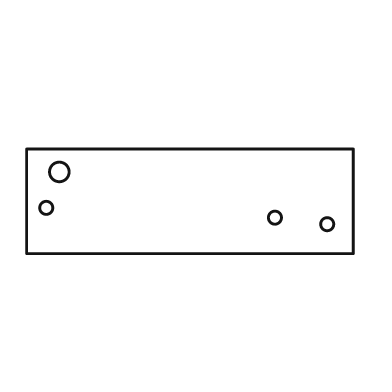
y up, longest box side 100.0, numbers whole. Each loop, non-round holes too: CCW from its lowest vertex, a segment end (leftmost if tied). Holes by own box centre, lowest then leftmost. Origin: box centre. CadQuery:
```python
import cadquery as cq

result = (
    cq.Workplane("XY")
    .moveTo(-50.0, -16.0)
    .lineTo(50.0, -16.0)
    .lineTo(50.0, 16.0)
    .lineTo(-50.0, 16.0)
    .close()
    .moveTo(42.0, -7.0)
    .circle(2.0)
    .moveTo(26.0, -5.0)
    .circle(2.0)
    .moveTo(-44.0, -2.0)
    .circle(2.0)
    .moveTo(-40.0, 9.0)
    .circle(3.0)
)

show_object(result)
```